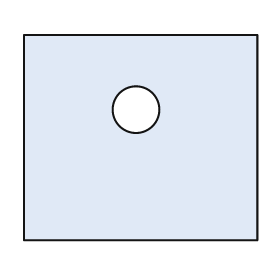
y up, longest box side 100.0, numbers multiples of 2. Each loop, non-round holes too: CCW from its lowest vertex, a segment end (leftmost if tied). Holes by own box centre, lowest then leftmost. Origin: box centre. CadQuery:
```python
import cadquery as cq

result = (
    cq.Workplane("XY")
    .moveTo(-50.0, -44.0)
    .lineTo(50.0, -44.0)
    .lineTo(50.0, 44.0)
    .lineTo(-50.0, 44.0)
    .close()
    .moveTo(-2.0, 12.0)
    .circle(10.0)
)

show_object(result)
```